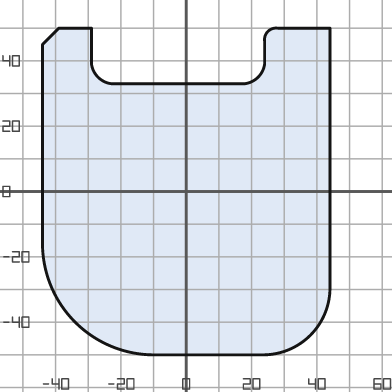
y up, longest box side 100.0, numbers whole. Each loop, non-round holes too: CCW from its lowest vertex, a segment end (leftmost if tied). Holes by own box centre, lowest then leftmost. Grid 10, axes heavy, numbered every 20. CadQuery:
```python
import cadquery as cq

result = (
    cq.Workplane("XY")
    .moveTo(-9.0, -50.0)
    .lineTo(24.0, -50.0)
    .threePointArc((38.0, -44.0), (44.0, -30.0))
    .lineTo(44.0, 50.0)
    .lineTo(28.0, 50.0)
    .threePointArc((25.0, 49.0), (24.0, 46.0))
    .lineTo(24.0, 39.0)
    .threePointArc((22.0, 35.0), (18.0, 33.0))
    .lineTo(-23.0, 33.0)
    .threePointArc((-27.0, 35.0), (-29.0, 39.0))
    .lineTo(-29.0, 50.0)
    .lineTo(-39.0, 50.0)
    .lineTo(-44.0, 45.0)
    .lineTo(-44.0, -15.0)
    .threePointArc((-34.0, -40.0), (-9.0, -50.0))
    .close()
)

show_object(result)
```